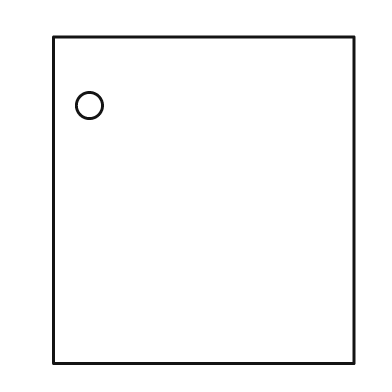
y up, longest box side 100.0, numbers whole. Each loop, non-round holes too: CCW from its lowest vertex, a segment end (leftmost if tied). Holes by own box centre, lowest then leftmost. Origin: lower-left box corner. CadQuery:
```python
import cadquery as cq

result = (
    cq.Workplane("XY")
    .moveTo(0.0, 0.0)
    .lineTo(92.0, 0.0)
    .lineTo(92.0, 100.0)
    .lineTo(0.0, 100.0)
    .close()
    .moveTo(11.0, 79.0)
    .circle(4.0)
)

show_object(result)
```